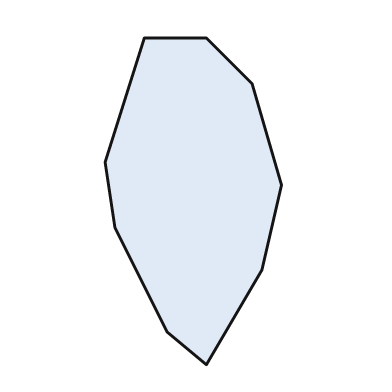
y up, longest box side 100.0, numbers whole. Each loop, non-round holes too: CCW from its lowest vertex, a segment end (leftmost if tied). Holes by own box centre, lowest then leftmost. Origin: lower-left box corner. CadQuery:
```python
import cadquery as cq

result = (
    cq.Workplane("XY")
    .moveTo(31.0, 0.0)
    .lineTo(48.0, 29.0)
    .lineTo(54.0, 55.0)
    .lineTo(45.0, 86.0)
    .lineTo(31.0, 100.0)
    .lineTo(12.0, 100.0)
    .lineTo(0.0, 62.0)
    .lineTo(3.0, 42.0)
    .lineTo(19.0, 10.0)
    .close()
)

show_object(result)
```